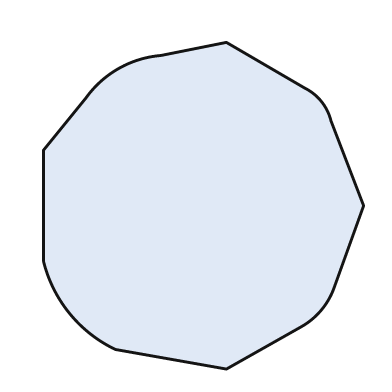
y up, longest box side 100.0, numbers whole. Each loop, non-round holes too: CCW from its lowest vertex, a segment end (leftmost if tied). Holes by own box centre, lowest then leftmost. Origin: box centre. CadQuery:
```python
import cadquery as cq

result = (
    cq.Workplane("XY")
    .moveTo(7.0, -50.0)
    .lineTo(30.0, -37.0)
    .threePointArc((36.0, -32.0), (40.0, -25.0))
    .lineTo(49.0, 0.0)
    .lineTo(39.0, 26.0)
    .threePointArc((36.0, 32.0), (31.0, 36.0))
    .lineTo(7.0, 50.0)
    .lineTo(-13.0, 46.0)
    .threePointArc((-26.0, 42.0), (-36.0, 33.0))
    .lineTo(-49.0, 17.0)
    .lineTo(-49.0, -17.0)
    .threePointArc((-41.0, -33.0), (-27.0, -44.0))
    .close()
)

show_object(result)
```